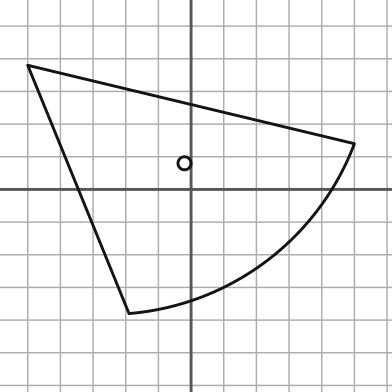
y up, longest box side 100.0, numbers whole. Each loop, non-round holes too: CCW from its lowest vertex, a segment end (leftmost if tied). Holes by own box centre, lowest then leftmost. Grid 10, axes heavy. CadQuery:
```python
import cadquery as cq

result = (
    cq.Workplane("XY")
    .moveTo(-19.0, -38.0)
    .threePointArc((23.0, -22.0), (50.0, 14.0))
    .lineTo(-50.0, 38.0)
    .close()
    .moveTo(-2.0, 8.0)
    .circle(2.0)
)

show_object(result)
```